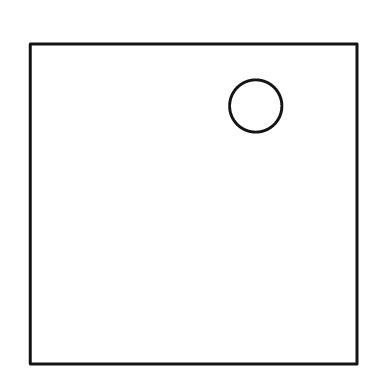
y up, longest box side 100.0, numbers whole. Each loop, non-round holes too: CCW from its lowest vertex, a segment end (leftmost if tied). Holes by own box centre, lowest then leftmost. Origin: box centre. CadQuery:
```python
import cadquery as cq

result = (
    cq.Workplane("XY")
    .moveTo(-50.0, -49.0)
    .lineTo(50.0, -49.0)
    .lineTo(50.0, 49.0)
    .lineTo(-50.0, 49.0)
    .close()
    .moveTo(19.0, 30.0)
    .circle(8.0)
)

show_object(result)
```